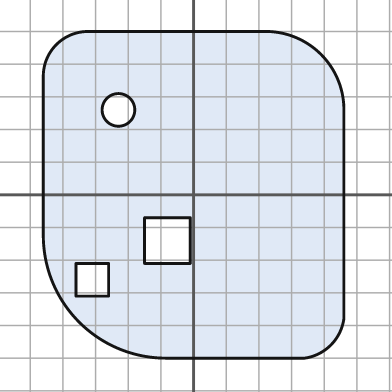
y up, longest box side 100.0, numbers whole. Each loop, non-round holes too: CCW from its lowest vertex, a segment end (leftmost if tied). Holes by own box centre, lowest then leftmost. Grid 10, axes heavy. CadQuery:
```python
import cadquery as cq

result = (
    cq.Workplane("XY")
    .moveTo(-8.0, -50.0)
    .lineTo(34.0, -50.0)
    .threePointArc((42.0, -46.0), (46.0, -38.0))
    .lineTo(46.0, 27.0)
    .threePointArc((39.0, 43.0), (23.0, 50.0))
    .lineTo(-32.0, 50.0)
    .threePointArc((-42.0, 46.0), (-46.0, 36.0))
    .lineTo(-46.0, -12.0)
    .threePointArc((-35.0, -39.0), (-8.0, -50.0))
    .close()
    .moveTo(-36.0, -31.0)
    .lineTo(-26.0, -31.0)
    .lineTo(-26.0, -21.0)
    .lineTo(-36.0, -21.0)
    .close()
    .moveTo(-15.0, -21.0)
    .lineTo(-1.0, -21.0)
    .lineTo(-1.0, -7.0)
    .lineTo(-15.0, -7.0)
    .close()
    .moveTo(-23.0, 26.0)
    .circle(5.0)
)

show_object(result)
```